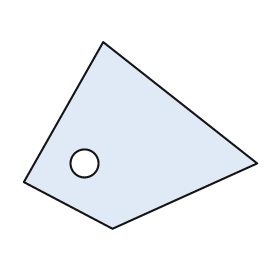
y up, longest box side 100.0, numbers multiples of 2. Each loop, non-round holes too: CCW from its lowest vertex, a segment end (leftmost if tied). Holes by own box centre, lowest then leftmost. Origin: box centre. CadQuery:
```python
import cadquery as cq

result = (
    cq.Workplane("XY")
    .moveTo(-12.0, -40.0)
    .lineTo(50.0, -12.0)
    .lineTo(-16.0, 40.0)
    .lineTo(-50.0, -20.0)
    .close()
    .moveTo(-24.0, -12.0)
    .circle(6.0)
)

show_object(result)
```